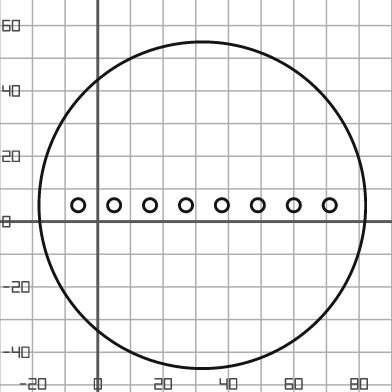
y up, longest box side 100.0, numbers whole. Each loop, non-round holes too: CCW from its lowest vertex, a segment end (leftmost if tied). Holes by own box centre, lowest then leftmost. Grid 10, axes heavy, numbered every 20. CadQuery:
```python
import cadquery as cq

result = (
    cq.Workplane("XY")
    .moveTo(32.0, 5.0)
    .circle(50.0)
    .moveTo(-6.0, 5.0)
    .circle(2.0)
    .moveTo(5.0, 5.0)
    .circle(2.0)
    .moveTo(16.0, 5.0)
    .circle(2.0)
    .moveTo(27.0, 5.0)
    .circle(2.0)
    .moveTo(38.0, 5.0)
    .circle(2.0)
    .moveTo(49.0, 5.0)
    .circle(2.0)
    .moveTo(60.0, 5.0)
    .circle(2.0)
    .moveTo(71.0, 5.0)
    .circle(2.0)
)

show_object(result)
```